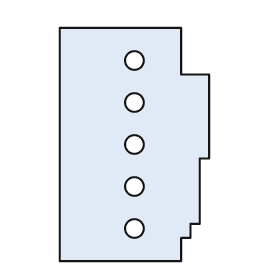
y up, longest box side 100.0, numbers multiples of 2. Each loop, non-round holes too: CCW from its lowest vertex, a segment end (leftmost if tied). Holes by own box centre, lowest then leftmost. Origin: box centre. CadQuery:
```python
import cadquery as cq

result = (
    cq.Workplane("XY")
    .moveTo(-32.0, -50.0)
    .lineTo(20.0, -50.0)
    .lineTo(20.0, -40.0)
    .lineTo(24.0, -40.0)
    .lineTo(24.0, -34.0)
    .lineTo(28.0, -34.0)
    .lineTo(28.0, -6.0)
    .lineTo(32.0, -6.0)
    .lineTo(32.0, 30.0)
    .lineTo(20.0, 30.0)
    .lineTo(20.0, 50.0)
    .lineTo(-32.0, 50.0)
    .close()
    .moveTo(0.0, -36.0)
    .circle(4.0)
    .moveTo(0.0, -18.0)
    .circle(4.0)
    .moveTo(0.0, 0.0)
    .circle(4.0)
    .moveTo(0.0, 18.0)
    .circle(4.0)
    .moveTo(0.0, 36.0)
    .circle(4.0)
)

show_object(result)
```